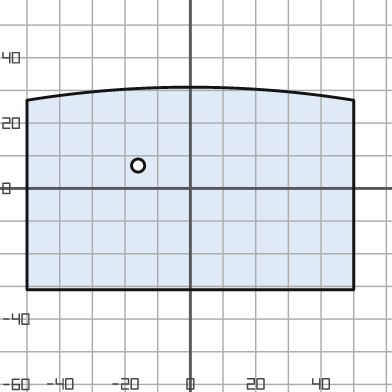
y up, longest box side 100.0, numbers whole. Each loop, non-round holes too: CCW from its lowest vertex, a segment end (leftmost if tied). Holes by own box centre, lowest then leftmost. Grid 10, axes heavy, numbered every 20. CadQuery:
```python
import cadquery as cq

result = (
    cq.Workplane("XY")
    .moveTo(-50.0, -31.0)
    .lineTo(50.0, -31.0)
    .lineTo(50.0, 27.0)
    .threePointArc((0.0, 31.0), (-50.0, 27.0))
    .close()
    .moveTo(-16.0, 7.0)
    .circle(2.0)
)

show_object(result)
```